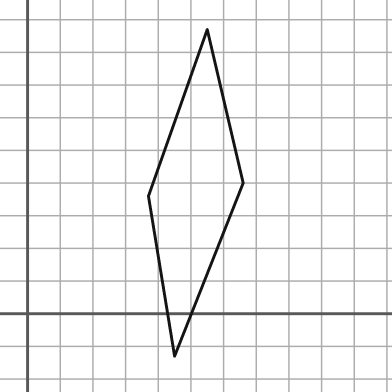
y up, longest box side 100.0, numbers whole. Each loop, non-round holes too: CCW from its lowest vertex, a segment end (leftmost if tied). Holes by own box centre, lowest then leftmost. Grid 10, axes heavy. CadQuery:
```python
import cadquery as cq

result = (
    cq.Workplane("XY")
    .moveTo(45.0, -13.0)
    .lineTo(66.0, 40.0)
    .lineTo(55.0, 87.0)
    .lineTo(37.0, 36.0)
    .close()
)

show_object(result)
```